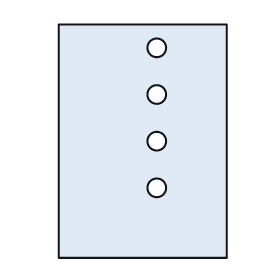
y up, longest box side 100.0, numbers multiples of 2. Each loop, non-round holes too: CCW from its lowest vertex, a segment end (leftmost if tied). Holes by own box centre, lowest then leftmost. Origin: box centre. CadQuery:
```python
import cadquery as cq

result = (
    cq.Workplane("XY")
    .moveTo(-36.0, -50.0)
    .lineTo(36.0, -50.0)
    .lineTo(36.0, 50.0)
    .lineTo(-36.0, 50.0)
    .close()
    .moveTo(6.0, -20.0)
    .circle(4.0)
    .moveTo(6.0, 0.0)
    .circle(4.0)
    .moveTo(6.0, 20.0)
    .circle(4.0)
    .moveTo(6.0, 40.0)
    .circle(4.0)
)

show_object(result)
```